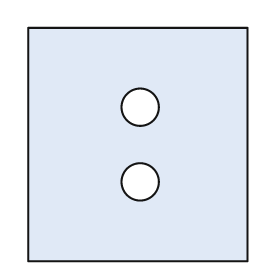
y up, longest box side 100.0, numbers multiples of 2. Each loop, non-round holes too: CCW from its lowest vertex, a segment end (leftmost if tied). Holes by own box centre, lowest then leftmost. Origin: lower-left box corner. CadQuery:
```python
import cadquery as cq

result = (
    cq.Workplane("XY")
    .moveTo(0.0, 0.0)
    .lineTo(94.0, 0.0)
    .lineTo(94.0, 100.0)
    .lineTo(0.0, 100.0)
    .close()
    .moveTo(48.0, 34.0)
    .circle(8.0)
    .moveTo(48.0, 66.0)
    .circle(8.0)
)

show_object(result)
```